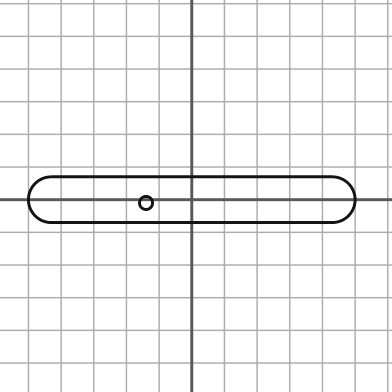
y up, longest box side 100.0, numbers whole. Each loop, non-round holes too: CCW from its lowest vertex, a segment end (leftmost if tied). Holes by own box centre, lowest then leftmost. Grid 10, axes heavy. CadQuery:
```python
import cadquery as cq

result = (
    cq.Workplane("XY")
    .moveTo(-43.0, -7.0)
    .lineTo(43.0, -7.0)
    .threePointArc((50.0, 0.0), (43.0, 7.0))
    .lineTo(-43.0, 7.0)
    .threePointArc((-50.0, 0.0), (-43.0, -7.0))
    .close()
    .moveTo(-14.0, -1.0)
    .circle(2.0)
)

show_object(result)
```